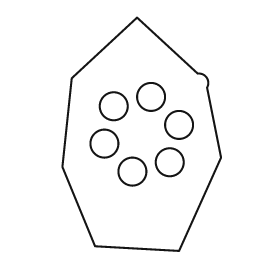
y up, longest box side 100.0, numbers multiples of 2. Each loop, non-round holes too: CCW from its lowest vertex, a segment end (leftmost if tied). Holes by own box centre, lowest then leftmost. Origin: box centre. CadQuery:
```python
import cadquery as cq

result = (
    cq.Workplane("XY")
    .moveTo(16.0, -50.0)
    .lineTo(34.0, -10.0)
    .lineTo(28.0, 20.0)
    .threePointArc((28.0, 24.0), (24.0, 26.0))
    .lineTo(-2.0, 50.0)
    .lineTo(-30.0, 24.0)
    .lineTo(-34.0, -14.0)
    .lineTo(-20.0, -48.0)
    .close()
    .moveTo(-4.0, -16.0)
    .circle(6.0)
    .moveTo(12.0, -12.0)
    .circle(6.0)
    .moveTo(-16.0, -4.0)
    .circle(6.0)
    .moveTo(16.0, 4.0)
    .circle(6.0)
    .moveTo(-12.0, 12.0)
    .circle(6.0)
    .moveTo(4.0, 16.0)
    .circle(6.0)
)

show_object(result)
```